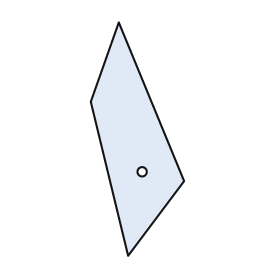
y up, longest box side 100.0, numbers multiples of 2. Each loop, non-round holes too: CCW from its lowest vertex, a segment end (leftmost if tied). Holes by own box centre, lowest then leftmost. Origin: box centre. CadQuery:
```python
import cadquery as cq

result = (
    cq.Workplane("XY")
    .moveTo(-4.0, -50.0)
    .lineTo(20.0, -18.0)
    .lineTo(-8.0, 50.0)
    .lineTo(-20.0, 16.0)
    .close()
    .moveTo(2.0, -14.0)
    .circle(2.0)
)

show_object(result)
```